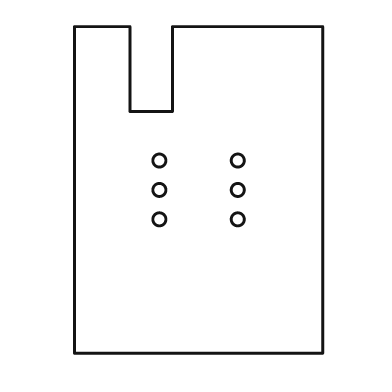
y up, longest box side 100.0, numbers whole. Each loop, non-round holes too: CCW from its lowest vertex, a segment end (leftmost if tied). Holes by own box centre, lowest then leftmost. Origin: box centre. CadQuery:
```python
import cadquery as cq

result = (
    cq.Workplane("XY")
    .moveTo(-38.0, -50.0)
    .lineTo(38.0, -50.0)
    .lineTo(38.0, 50.0)
    .lineTo(-8.0, 50.0)
    .lineTo(-8.0, 24.0)
    .lineTo(-21.0, 24.0)
    .lineTo(-21.0, 50.0)
    .lineTo(-38.0, 50.0)
    .close()
    .moveTo(-12.0, -9.0)
    .circle(2.0)
    .moveTo(12.0, -9.0)
    .circle(2.0)
    .moveTo(-12.0, 0.0)
    .circle(2.0)
    .moveTo(12.0, 0.0)
    .circle(2.0)
    .moveTo(-12.0, 9.0)
    .circle(2.0)
    .moveTo(12.0, 9.0)
    .circle(2.0)
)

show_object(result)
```